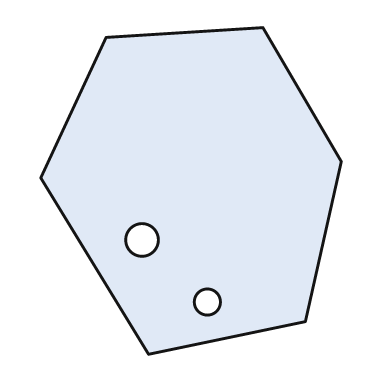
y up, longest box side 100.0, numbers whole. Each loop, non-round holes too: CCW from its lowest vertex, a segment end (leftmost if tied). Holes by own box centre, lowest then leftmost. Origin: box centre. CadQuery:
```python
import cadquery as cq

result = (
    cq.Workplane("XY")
    .moveTo(-13.0, -50.0)
    .lineTo(35.0, -40.0)
    .lineTo(46.0, 9.0)
    .lineTo(22.0, 50.0)
    .lineTo(-26.0, 47.0)
    .lineTo(-46.0, 4.0)
    .close()
    .moveTo(5.0, -34.0)
    .circle(4.0)
    .moveTo(-15.0, -15.0)
    .circle(5.0)
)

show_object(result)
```